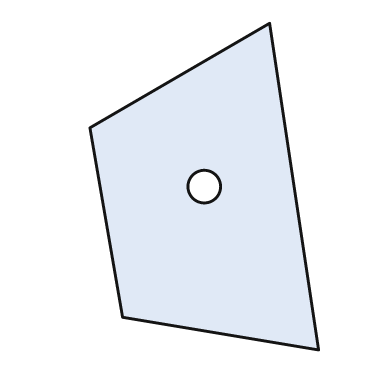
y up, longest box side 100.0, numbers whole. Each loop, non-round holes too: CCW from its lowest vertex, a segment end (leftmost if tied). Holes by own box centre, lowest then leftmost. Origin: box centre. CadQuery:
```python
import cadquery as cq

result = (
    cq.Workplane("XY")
    .moveTo(35.0, -50.0)
    .lineTo(20.0, 50.0)
    .lineTo(-35.0, 18.0)
    .lineTo(-25.0, -40.0)
    .close()
    .moveTo(0.0, 0.0)
    .circle(5.0)
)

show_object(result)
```